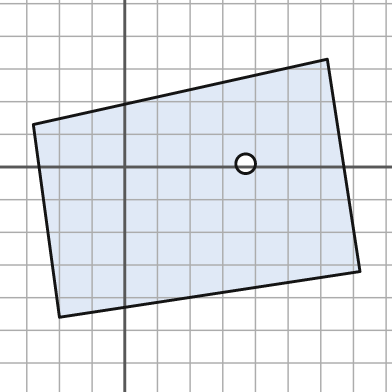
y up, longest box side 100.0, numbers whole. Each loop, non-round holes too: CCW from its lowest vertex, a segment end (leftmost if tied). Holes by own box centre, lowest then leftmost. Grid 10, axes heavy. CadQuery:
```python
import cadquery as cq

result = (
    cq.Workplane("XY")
    .moveTo(-20.0, -46.0)
    .lineTo(72.0, -32.0)
    .lineTo(62.0, 33.0)
    .lineTo(-28.0, 13.0)
    .close()
    .moveTo(37.0, 1.0)
    .circle(3.0)
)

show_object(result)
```